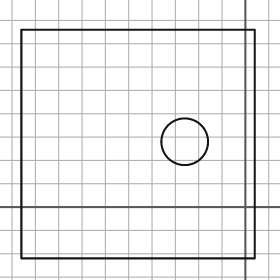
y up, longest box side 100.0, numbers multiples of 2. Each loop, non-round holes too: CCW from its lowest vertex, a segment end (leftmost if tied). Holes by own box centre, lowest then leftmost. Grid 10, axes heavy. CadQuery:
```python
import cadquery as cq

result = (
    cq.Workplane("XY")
    .moveTo(-96.0, -22.0)
    .lineTo(4.0, -22.0)
    .lineTo(4.0, 76.0)
    .lineTo(-96.0, 76.0)
    .close()
    .moveTo(-26.0, 28.0)
    .circle(10.0)
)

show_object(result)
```